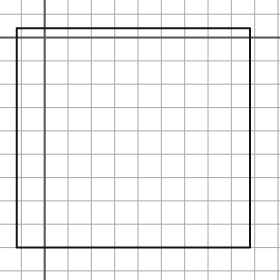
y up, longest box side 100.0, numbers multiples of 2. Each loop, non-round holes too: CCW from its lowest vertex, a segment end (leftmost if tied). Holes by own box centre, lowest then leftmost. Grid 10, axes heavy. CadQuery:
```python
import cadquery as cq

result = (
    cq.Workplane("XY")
    .moveTo(-12.0, -90.0)
    .lineTo(88.0, -90.0)
    .lineTo(88.0, 4.0)
    .lineTo(-12.0, 4.0)
    .close()
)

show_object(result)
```